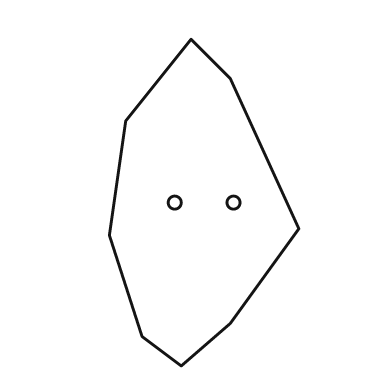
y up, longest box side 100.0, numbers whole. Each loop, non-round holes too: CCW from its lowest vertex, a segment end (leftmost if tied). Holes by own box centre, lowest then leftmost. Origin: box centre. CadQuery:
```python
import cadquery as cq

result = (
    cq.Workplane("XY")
    .moveTo(-7.0, -50.0)
    .lineTo(8.0, -37.0)
    .lineTo(29.0, -8.0)
    .lineTo(8.0, 38.0)
    .lineTo(-4.0, 50.0)
    .lineTo(-24.0, 25.0)
    .lineTo(-29.0, -10.0)
    .lineTo(-19.0, -41.0)
    .close()
    .moveTo(-9.0, 0.0)
    .circle(2.0)
    .moveTo(9.0, 0.0)
    .circle(2.0)
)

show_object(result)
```